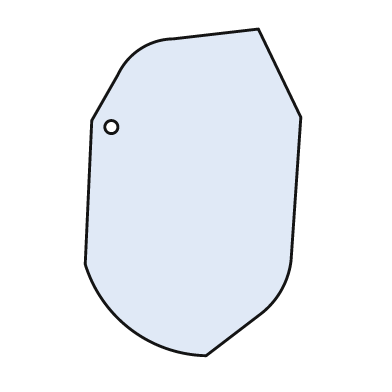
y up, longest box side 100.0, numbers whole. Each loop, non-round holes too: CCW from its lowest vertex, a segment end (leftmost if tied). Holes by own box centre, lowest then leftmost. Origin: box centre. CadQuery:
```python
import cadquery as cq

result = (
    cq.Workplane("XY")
    .moveTo(4.0, -50.0)
    .lineTo(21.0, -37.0)
    .threePointArc((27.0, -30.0), (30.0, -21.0))
    .lineTo(33.0, 23.0)
    .lineTo(20.0, 50.0)
    .lineTo(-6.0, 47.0)
    .threePointArc((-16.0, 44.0), (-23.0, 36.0))
    .lineTo(-31.0, 22.0)
    .lineTo(-33.0, -22.0)
    .threePointArc((-19.0, -42.0), (4.0, -50.0))
    .close()
    .moveTo(-25.0, 20.0)
    .circle(2.0)
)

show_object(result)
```